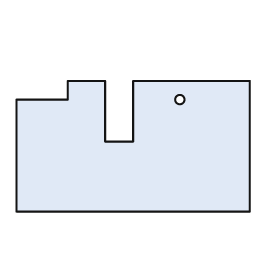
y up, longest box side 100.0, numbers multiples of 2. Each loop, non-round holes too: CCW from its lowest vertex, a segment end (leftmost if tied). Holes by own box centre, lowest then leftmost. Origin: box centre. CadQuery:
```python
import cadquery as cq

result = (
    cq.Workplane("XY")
    .moveTo(-50.0, -28.0)
    .lineTo(50.0, -28.0)
    .lineTo(50.0, 28.0)
    .lineTo(0.0, 28.0)
    .lineTo(0.0, 2.0)
    .lineTo(-12.0, 2.0)
    .lineTo(-12.0, 28.0)
    .lineTo(-28.0, 28.0)
    .lineTo(-28.0, 20.0)
    .lineTo(-50.0, 20.0)
    .close()
    .moveTo(20.0, 20.0)
    .circle(2.0)
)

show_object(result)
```